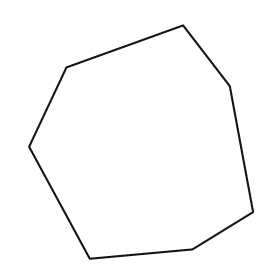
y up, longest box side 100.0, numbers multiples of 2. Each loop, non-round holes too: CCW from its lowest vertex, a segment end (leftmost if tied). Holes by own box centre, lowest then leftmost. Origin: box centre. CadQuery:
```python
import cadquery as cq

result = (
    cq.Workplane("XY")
    .moveTo(-22.0, -50.0)
    .lineTo(22.0, -46.0)
    .lineTo(48.0, -30.0)
    .lineTo(38.0, 24.0)
    .lineTo(18.0, 50.0)
    .lineTo(-32.0, 32.0)
    .lineTo(-48.0, -2.0)
    .close()
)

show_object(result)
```